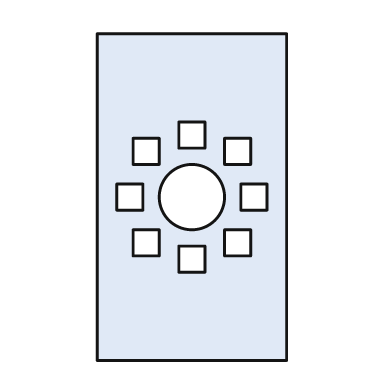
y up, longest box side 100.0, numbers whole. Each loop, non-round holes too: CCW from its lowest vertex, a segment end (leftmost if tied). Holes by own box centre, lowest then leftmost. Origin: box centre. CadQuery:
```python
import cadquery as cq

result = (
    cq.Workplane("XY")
    .moveTo(-29.0, -50.0)
    .lineTo(29.0, -50.0)
    .lineTo(29.0, 50.0)
    .lineTo(-29.0, 50.0)
    .close()
    .moveTo(-4.0, -23.0)
    .lineTo(4.0, -23.0)
    .lineTo(4.0, -15.0)
    .lineTo(-4.0, -15.0)
    .close()
    .moveTo(-18.0, -18.0)
    .lineTo(-10.0, -18.0)
    .lineTo(-10.0, -10.0)
    .lineTo(-18.0, -10.0)
    .close()
    .moveTo(10.0, -18.0)
    .lineTo(18.0, -18.0)
    .lineTo(18.0, -10.0)
    .lineTo(10.0, -10.0)
    .close()
    .moveTo(-23.0, -4.0)
    .lineTo(-15.0, -4.0)
    .lineTo(-15.0, 4.0)
    .lineTo(-23.0, 4.0)
    .close()
    .moveTo(0.0, 0.0)
    .circle(10.0)
    .moveTo(15.0, -4.0)
    .lineTo(23.0, -4.0)
    .lineTo(23.0, 4.0)
    .lineTo(15.0, 4.0)
    .close()
    .moveTo(-18.0, 10.0)
    .lineTo(-10.0, 10.0)
    .lineTo(-10.0, 18.0)
    .lineTo(-18.0, 18.0)
    .close()
    .moveTo(10.0, 10.0)
    .lineTo(18.0, 10.0)
    .lineTo(18.0, 18.0)
    .lineTo(10.0, 18.0)
    .close()
    .moveTo(-4.0, 15.0)
    .lineTo(4.0, 15.0)
    .lineTo(4.0, 23.0)
    .lineTo(-4.0, 23.0)
    .close()
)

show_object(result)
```